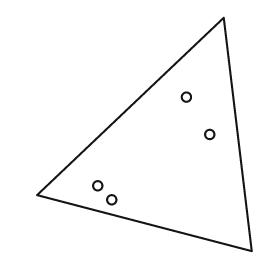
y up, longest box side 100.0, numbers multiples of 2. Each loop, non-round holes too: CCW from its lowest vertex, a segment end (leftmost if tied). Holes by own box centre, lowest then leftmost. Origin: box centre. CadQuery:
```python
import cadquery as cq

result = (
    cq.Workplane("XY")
    .moveTo(46.0, -50.0)
    .lineTo(34.0, 50.0)
    .lineTo(-46.0, -26.0)
    .close()
    .moveTo(-14.0, -28.0)
    .circle(2.0)
    .moveTo(-20.0, -22.0)
    .circle(2.0)
    .moveTo(28.0, 0.0)
    .circle(2.0)
    .moveTo(18.0, 16.0)
    .circle(2.0)
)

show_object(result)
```